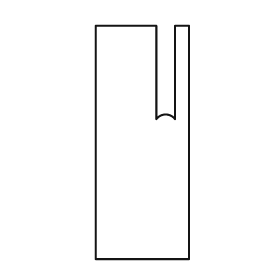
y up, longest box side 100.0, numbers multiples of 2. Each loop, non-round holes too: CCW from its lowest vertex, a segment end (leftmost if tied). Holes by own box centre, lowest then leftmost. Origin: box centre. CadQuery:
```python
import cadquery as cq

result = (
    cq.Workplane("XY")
    .moveTo(-20.0, -50.0)
    .lineTo(20.0, -50.0)
    .lineTo(20.0, 50.0)
    .lineTo(14.0, 50.0)
    .lineTo(14.0, 10.0)
    .threePointArc((10.0, 12.0), (6.0, 10.0))
    .lineTo(6.0, 50.0)
    .lineTo(-20.0, 50.0)
    .close()
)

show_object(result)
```